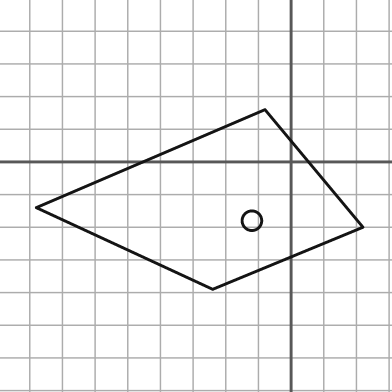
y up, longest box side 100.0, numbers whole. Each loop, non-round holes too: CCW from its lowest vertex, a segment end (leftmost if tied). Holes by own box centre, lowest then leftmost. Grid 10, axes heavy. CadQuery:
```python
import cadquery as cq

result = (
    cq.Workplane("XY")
    .moveTo(-24.0, -39.0)
    .lineTo(22.0, -20.0)
    .lineTo(-8.0, 16.0)
    .lineTo(-78.0, -14.0)
    .close()
    .moveTo(-12.0, -18.0)
    .circle(3.0)
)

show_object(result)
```